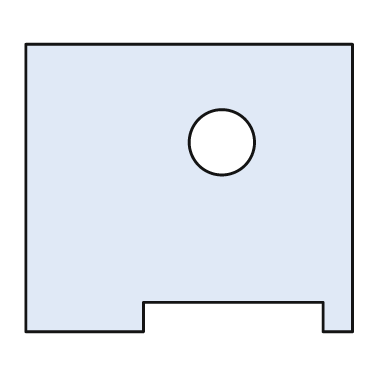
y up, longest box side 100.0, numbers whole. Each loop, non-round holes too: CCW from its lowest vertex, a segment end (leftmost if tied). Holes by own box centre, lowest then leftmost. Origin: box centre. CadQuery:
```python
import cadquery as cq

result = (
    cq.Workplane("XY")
    .moveTo(-50.0, -44.0)
    .lineTo(-14.0, -44.0)
    .lineTo(-14.0, -35.0)
    .lineTo(41.0, -35.0)
    .lineTo(41.0, -44.0)
    .lineTo(50.0, -44.0)
    .lineTo(50.0, 44.0)
    .lineTo(-50.0, 44.0)
    .close()
    .moveTo(10.0, 14.0)
    .circle(10.0)
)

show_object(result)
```